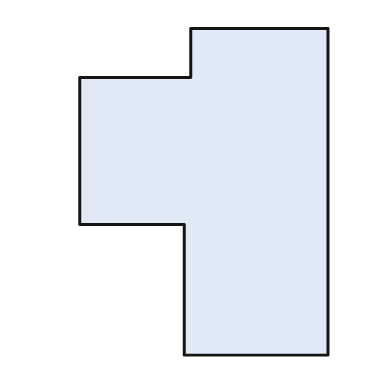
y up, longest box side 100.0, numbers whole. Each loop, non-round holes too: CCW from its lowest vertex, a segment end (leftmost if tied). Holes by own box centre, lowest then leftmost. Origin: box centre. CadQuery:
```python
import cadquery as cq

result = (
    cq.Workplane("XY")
    .moveTo(-6.0, -50.0)
    .lineTo(38.0, -50.0)
    .lineTo(38.0, 50.0)
    .lineTo(-4.0, 50.0)
    .lineTo(-4.0, 35.0)
    .lineTo(-38.0, 35.0)
    .lineTo(-38.0, -10.0)
    .lineTo(-6.0, -10.0)
    .close()
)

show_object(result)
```